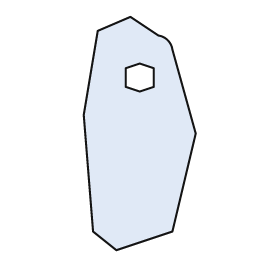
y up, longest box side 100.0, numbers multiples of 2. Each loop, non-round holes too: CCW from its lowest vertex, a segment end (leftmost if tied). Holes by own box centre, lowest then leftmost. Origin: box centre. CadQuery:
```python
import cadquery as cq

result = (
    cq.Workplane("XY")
    .moveTo(-10.0, -50.0)
    .lineTo(14.0, -42.0)
    .lineTo(24.0, 0.0)
    .lineTo(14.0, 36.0)
    .threePointArc((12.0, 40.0), (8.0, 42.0))
    .lineTo(-4.0, 50.0)
    .lineTo(-18.0, 44.0)
    .lineTo(-24.0, 8.0)
    .lineTo(-20.0, -42.0)
    .close()
    .moveTo(0.0, 18.0)
    .lineTo(6.0, 20.0)
    .lineTo(6.0, 28.0)
    .lineTo(0.0, 30.0)
    .lineTo(-6.0, 28.0)
    .lineTo(-6.0, 20.0)
    .close()
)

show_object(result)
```